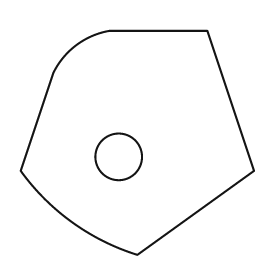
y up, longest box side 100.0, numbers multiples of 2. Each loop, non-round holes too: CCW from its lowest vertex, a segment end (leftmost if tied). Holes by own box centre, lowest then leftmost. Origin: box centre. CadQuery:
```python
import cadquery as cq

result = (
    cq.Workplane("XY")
    .moveTo(0.0, -48.0)
    .lineTo(50.0, -12.0)
    .lineTo(30.0, 48.0)
    .lineTo(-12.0, 48.0)
    .threePointArc((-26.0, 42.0), (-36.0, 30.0))
    .lineTo(-50.0, -12.0)
    .threePointArc((-28.0, -34.0), (0.0, -48.0))
    .close()
    .moveTo(-8.0, -6.0)
    .circle(10.0)
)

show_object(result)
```